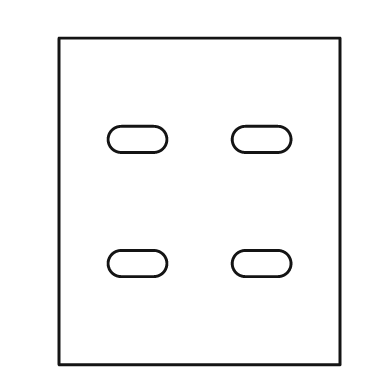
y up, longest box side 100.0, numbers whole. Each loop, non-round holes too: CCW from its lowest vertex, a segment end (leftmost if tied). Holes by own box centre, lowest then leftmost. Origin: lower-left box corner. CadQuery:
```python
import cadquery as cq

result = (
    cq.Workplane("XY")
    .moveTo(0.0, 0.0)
    .lineTo(86.0, 0.0)
    .lineTo(86.0, 100.0)
    .lineTo(0.0, 100.0)
    .close()
    .moveTo(19.0, 27.0)
    .lineTo(29.0, 27.0)
    .threePointArc((33.0, 31.0), (29.0, 35.0))
    .lineTo(19.0, 35.0)
    .threePointArc((15.0, 31.0), (19.0, 27.0))
    .close()
    .moveTo(57.0, 27.0)
    .lineTo(67.0, 27.0)
    .threePointArc((71.0, 31.0), (67.0, 35.0))
    .lineTo(57.0, 35.0)
    .threePointArc((53.0, 31.0), (57.0, 27.0))
    .close()
    .moveTo(19.0, 65.0)
    .lineTo(29.0, 65.0)
    .threePointArc((33.0, 69.0), (29.0, 73.0))
    .lineTo(19.0, 73.0)
    .threePointArc((15.0, 69.0), (19.0, 65.0))
    .close()
    .moveTo(57.0, 65.0)
    .lineTo(67.0, 65.0)
    .threePointArc((71.0, 69.0), (67.0, 73.0))
    .lineTo(57.0, 73.0)
    .threePointArc((53.0, 69.0), (57.0, 65.0))
    .close()
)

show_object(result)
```